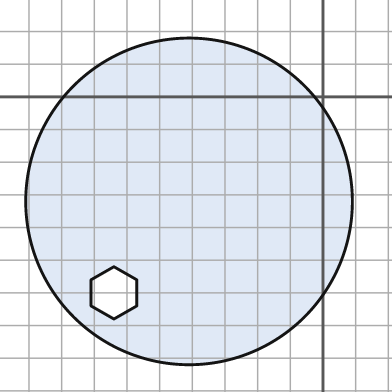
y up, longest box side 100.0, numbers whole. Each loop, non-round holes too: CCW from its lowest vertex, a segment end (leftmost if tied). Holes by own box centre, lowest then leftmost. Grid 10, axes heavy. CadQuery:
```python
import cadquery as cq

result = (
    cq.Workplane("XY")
    .moveTo(-41.0, -32.0)
    .circle(50.0)
    .moveTo(-64.0, -68.0)
    .lineTo(-57.0, -64.0)
    .lineTo(-57.0, -56.0)
    .lineTo(-64.0, -52.0)
    .lineTo(-71.0, -56.0)
    .lineTo(-71.0, -64.0)
    .close()
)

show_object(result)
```